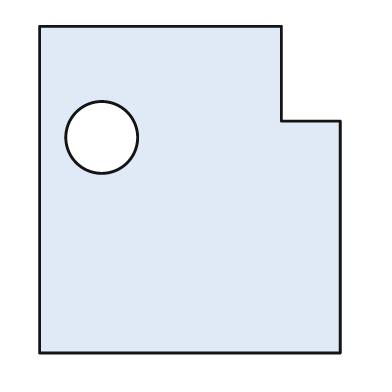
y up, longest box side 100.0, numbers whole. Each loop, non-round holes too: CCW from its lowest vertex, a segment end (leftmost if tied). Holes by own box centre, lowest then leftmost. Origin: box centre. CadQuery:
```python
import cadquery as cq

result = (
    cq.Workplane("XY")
    .moveTo(-46.0, -50.0)
    .lineTo(46.0, -50.0)
    .lineTo(46.0, 21.0)
    .lineTo(28.0, 21.0)
    .lineTo(28.0, 50.0)
    .lineTo(-46.0, 50.0)
    .close()
    .moveTo(-27.0, 16.0)
    .circle(11.0)
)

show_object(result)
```